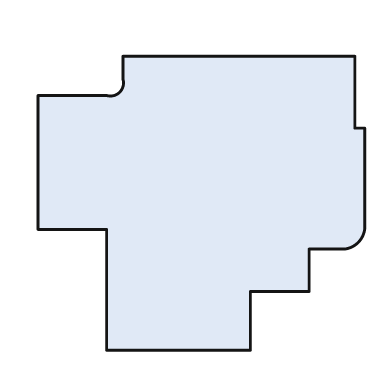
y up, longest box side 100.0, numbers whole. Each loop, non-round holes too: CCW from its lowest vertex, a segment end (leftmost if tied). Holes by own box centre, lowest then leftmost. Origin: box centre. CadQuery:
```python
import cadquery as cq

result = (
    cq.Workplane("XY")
    .moveTo(-29.0, -45.0)
    .lineTo(15.0, -45.0)
    .lineTo(15.0, -27.0)
    .lineTo(33.0, -27.0)
    .lineTo(33.0, -14.0)
    .lineTo(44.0, -14.0)
    .threePointArc((48.0, -12.0), (50.0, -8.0))
    .lineTo(50.0, 23.0)
    .lineTo(47.0, 23.0)
    .lineTo(47.0, 45.0)
    .lineTo(-24.0, 45.0)
    .lineTo(-24.0, 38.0)
    .threePointArc((-25.0, 34.0), (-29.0, 33.0))
    .lineTo(-50.0, 33.0)
    .lineTo(-50.0, -8.0)
    .lineTo(-29.0, -8.0)
    .close()
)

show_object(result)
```